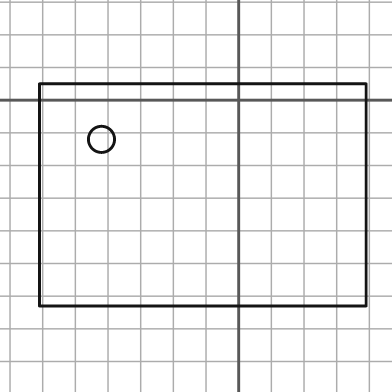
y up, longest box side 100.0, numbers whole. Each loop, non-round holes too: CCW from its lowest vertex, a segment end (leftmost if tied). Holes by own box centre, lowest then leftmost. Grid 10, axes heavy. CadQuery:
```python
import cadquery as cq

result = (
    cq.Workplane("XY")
    .moveTo(-61.0, -63.0)
    .lineTo(39.0, -63.0)
    .lineTo(39.0, 5.0)
    .lineTo(-61.0, 5.0)
    .close()
    .moveTo(-42.0, -12.0)
    .circle(4.0)
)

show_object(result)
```